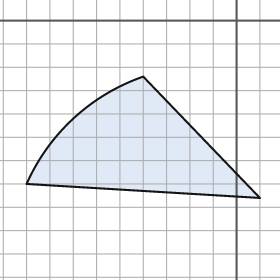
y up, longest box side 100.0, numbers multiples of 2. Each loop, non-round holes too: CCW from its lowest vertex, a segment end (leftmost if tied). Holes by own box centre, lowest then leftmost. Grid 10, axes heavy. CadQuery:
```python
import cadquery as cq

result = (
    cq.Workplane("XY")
    .moveTo(10.0, -76.0)
    .lineTo(-40.0, -24.0)
    .threePointArc((-70.0, -42.0), (-90.0, -70.0))
    .close()
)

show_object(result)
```